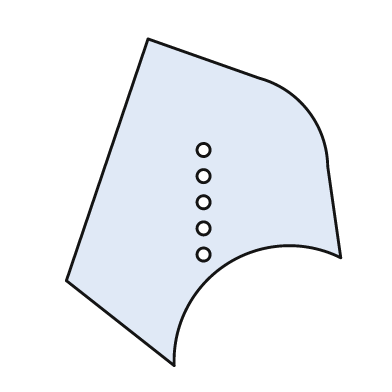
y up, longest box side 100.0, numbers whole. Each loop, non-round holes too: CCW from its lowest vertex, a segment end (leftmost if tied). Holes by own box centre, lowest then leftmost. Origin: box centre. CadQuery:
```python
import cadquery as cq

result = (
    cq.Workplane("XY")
    .moveTo(-9.0, -50.0)
    .threePointArc((7.0, -19.0), (42.0, -17.0))
    .lineTo(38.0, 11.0)
    .threePointArc((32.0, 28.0), (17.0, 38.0))
    .lineTo(-17.0, 50.0)
    .lineTo(-42.0, -24.0)
    .close()
    .moveTo(0.0, -16.0)
    .circle(2.0)
    .moveTo(0.0, -8.0)
    .circle(2.0)
    .moveTo(0.0, 0.0)
    .circle(2.0)
    .moveTo(0.0, 8.0)
    .circle(2.0)
    .moveTo(0.0, 16.0)
    .circle(2.0)
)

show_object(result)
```